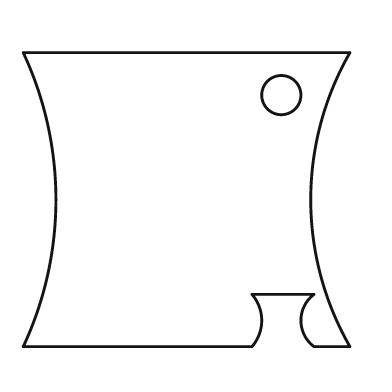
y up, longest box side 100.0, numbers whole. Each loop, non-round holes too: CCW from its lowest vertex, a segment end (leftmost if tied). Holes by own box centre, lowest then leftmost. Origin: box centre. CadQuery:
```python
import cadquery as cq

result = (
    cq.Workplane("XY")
    .moveTo(-50.0, -45.0)
    .lineTo(20.0, -45.0)
    .threePointArc((23.0, -37.0), (20.0, -29.0))
    .lineTo(39.0, -29.0)
    .threePointArc((35.0, -37.0), (39.0, -45.0))
    .lineTo(50.0, -45.0)
    .threePointArc((38.0, 0.0), (50.0, 45.0))
    .lineTo(-50.0, 45.0)
    .threePointArc((-40.0, 0.0), (-50.0, -45.0))
    .close()
    .moveTo(29.0, 32.0)
    .circle(6.0)
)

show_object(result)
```